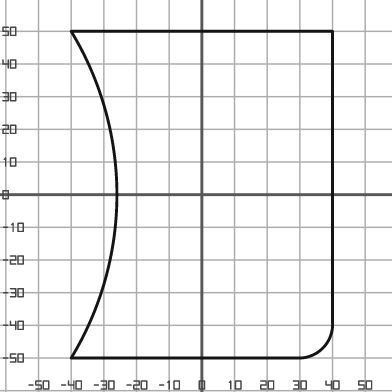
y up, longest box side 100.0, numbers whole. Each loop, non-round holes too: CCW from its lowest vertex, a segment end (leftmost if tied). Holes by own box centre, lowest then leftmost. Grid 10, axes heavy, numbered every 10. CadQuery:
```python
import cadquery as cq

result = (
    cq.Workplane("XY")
    .moveTo(-40.0, -50.0)
    .lineTo(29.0, -50.0)
    .threePointArc((37.0, -47.0), (40.0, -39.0))
    .lineTo(40.0, 50.0)
    .lineTo(-40.0, 50.0)
    .threePointArc((-26.0, 0.0), (-40.0, -50.0))
    .close()
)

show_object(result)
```